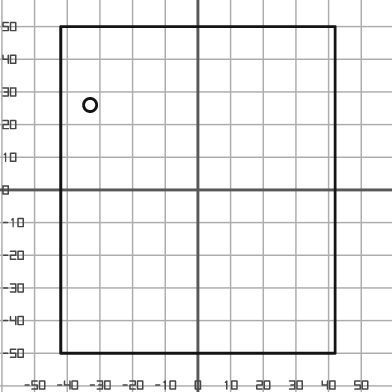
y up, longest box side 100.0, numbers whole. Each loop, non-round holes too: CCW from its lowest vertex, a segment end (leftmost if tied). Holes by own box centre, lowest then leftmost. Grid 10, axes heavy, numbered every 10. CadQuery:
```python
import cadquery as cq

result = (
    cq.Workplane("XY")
    .moveTo(-42.0, -50.0)
    .lineTo(42.0, -50.0)
    .lineTo(42.0, 50.0)
    .lineTo(-42.0, 50.0)
    .close()
    .moveTo(-33.0, 26.0)
    .circle(2.0)
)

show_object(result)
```